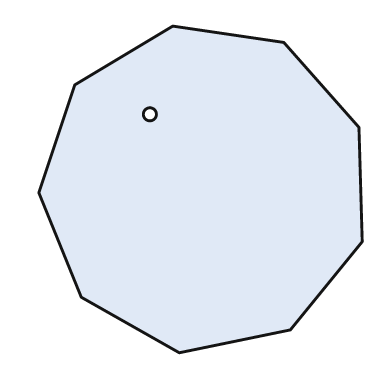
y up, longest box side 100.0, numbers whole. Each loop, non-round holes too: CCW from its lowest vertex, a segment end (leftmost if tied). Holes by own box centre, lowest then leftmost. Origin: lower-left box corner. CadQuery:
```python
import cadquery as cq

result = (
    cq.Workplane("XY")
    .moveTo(43.0, 0.0)
    .lineTo(77.0, 7.0)
    .lineTo(99.0, 34.0)
    .lineTo(98.0, 69.0)
    .lineTo(75.0, 95.0)
    .lineTo(41.0, 100.0)
    .lineTo(11.0, 82.0)
    .lineTo(0.0, 49.0)
    .lineTo(13.0, 17.0)
    .close()
    .moveTo(34.0, 73.0)
    .circle(2.0)
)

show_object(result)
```